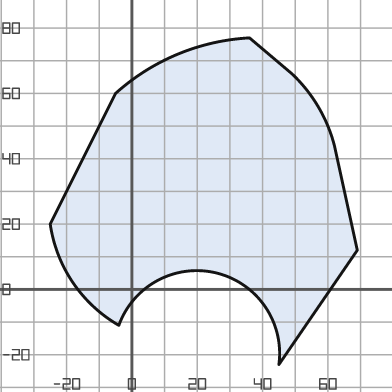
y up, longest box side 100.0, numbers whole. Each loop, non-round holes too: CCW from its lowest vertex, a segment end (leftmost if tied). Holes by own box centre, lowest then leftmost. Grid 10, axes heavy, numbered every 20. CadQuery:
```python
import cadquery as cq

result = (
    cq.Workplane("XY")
    .moveTo(45.0, -23.0)
    .lineTo(69.0, 12.0)
    .lineTo(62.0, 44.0)
    .threePointArc((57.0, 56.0), (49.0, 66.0))
    .lineTo(36.0, 77.0)
    .threePointArc((14.0, 72.0), (-5.0, 60.0))
    .lineTo(-25.0, 20.0)
    .threePointArc((-18.0, 2.0), (-4.0, -11.0))
    .threePointArc((26.0, 5.0), (45.0, -23.0))
    .close()
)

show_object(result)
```